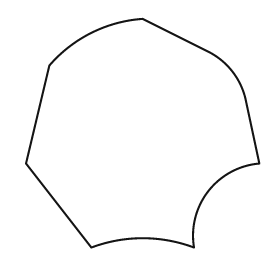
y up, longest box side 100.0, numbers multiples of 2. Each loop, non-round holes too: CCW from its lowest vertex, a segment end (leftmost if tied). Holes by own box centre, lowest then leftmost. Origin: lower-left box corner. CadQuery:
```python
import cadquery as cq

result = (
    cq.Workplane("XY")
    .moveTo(28.0, 0.0)
    .threePointArc((50.0, 4.0), (72.0, 0.0))
    .threePointArc((78.0, 24.0), (100.0, 36.0))
    .lineTo(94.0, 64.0)
    .threePointArc((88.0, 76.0), (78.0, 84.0))
    .lineTo(50.0, 98.0)
    .threePointArc((28.0, 92.0), (10.0, 78.0))
    .lineTo(0.0, 36.0)
    .close()
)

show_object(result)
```